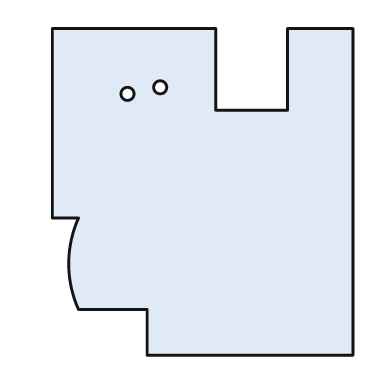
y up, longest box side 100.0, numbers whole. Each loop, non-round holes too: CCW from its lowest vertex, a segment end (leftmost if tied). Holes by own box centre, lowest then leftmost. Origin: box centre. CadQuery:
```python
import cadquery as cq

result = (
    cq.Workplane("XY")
    .moveTo(-17.0, -50.0)
    .lineTo(46.0, -50.0)
    .lineTo(46.0, 50.0)
    .lineTo(26.0, 50.0)
    .lineTo(26.0, 25.0)
    .lineTo(4.0, 25.0)
    .lineTo(4.0, 50.0)
    .lineTo(-46.0, 50.0)
    .lineTo(-46.0, -8.0)
    .lineTo(-38.0, -8.0)
    .threePointArc((-41.0, -22.0), (-38.0, -36.0))
    .lineTo(-17.0, -36.0)
    .close()
    .moveTo(-23.0, 30.0)
    .circle(2.0)
    .moveTo(-13.0, 32.0)
    .circle(2.0)
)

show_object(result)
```